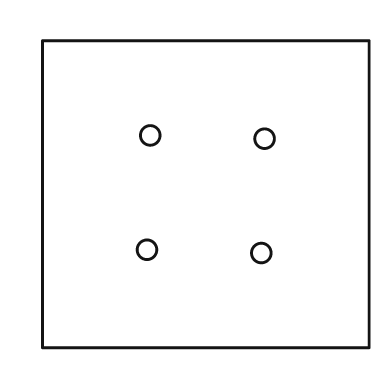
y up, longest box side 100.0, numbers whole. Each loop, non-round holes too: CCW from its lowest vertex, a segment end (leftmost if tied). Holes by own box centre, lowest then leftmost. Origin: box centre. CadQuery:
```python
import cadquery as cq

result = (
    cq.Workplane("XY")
    .moveTo(-50.0, -47.0)
    .lineTo(50.0, -47.0)
    .lineTo(50.0, 47.0)
    .lineTo(-50.0, 47.0)
    .close()
    .moveTo(17.0, -18.0)
    .circle(3.0)
    .moveTo(-18.0, -17.0)
    .circle(3.0)
    .moveTo(18.0, 17.0)
    .circle(3.0)
    .moveTo(-17.0, 18.0)
    .circle(3.0)
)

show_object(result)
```